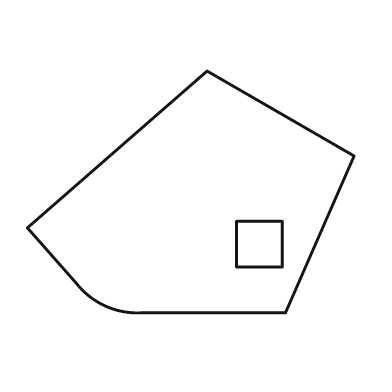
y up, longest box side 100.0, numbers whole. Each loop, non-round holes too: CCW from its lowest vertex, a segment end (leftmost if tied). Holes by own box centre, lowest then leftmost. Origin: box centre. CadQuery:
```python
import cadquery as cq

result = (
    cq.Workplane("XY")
    .moveTo(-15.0, -37.0)
    .lineTo(29.0, -37.0)
    .lineTo(50.0, 11.0)
    .lineTo(5.0, 37.0)
    .lineTo(-50.0, -11.0)
    .lineTo(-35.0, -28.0)
    .threePointArc((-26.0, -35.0), (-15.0, -37.0))
    .close()
    .moveTo(14.0, -23.0)
    .lineTo(28.0, -23.0)
    .lineTo(28.0, -9.0)
    .lineTo(14.0, -9.0)
    .close()
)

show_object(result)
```